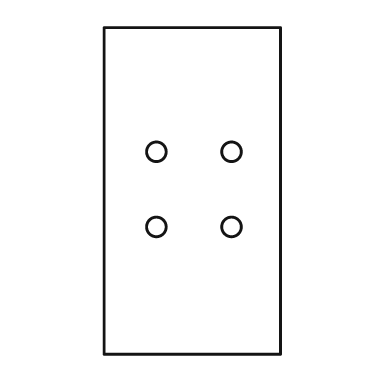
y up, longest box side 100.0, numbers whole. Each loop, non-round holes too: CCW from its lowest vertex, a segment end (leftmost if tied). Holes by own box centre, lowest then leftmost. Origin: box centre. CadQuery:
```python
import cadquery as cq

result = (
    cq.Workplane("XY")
    .moveTo(-27.0, -50.0)
    .lineTo(27.0, -50.0)
    .lineTo(27.0, 50.0)
    .lineTo(-27.0, 50.0)
    .close()
    .moveTo(-11.0, -11.0)
    .circle(3.0)
    .moveTo(12.0, -11.0)
    .circle(3.0)
    .moveTo(-11.0, 12.0)
    .circle(3.0)
    .moveTo(12.0, 12.0)
    .circle(3.0)
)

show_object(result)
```